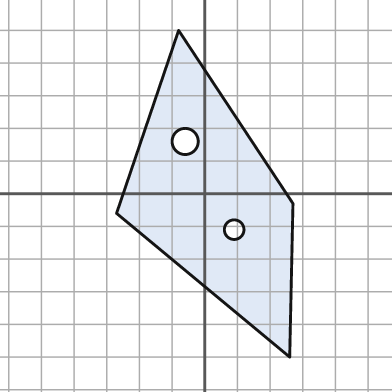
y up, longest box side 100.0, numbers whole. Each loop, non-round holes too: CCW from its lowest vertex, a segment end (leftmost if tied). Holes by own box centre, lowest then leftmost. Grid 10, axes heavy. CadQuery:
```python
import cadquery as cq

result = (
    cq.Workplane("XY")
    .moveTo(26.0, -50.0)
    .lineTo(27.0, -3.0)
    .lineTo(-8.0, 50.0)
    .lineTo(-27.0, -6.0)
    .close()
    .moveTo(9.0, -11.0)
    .circle(3.0)
    .moveTo(-6.0, 16.0)
    .circle(4.0)
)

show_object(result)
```